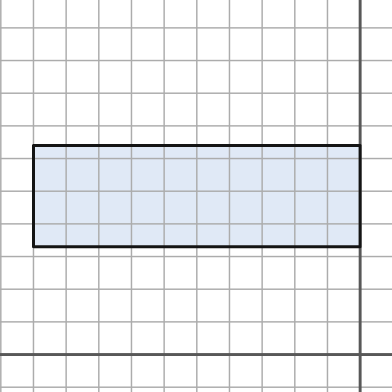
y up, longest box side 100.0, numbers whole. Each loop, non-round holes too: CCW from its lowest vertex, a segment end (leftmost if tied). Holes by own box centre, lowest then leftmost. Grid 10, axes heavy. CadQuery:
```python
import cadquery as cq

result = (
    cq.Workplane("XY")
    .moveTo(-100.0, 33.0)
    .lineTo(0.0, 33.0)
    .lineTo(0.0, 64.0)
    .lineTo(-100.0, 64.0)
    .close()
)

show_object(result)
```